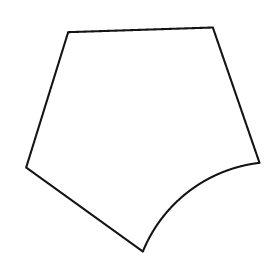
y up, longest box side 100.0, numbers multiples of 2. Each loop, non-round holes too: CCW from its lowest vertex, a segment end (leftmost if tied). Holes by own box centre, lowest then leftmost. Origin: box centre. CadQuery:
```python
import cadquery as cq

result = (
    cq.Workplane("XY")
    .moveTo(0.0, -48.0)
    .threePointArc((20.0, -22.0), (50.0, -10.0))
    .lineTo(30.0, 48.0)
    .lineTo(-32.0, 46.0)
    .lineTo(-50.0, -12.0)
    .close()
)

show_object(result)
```